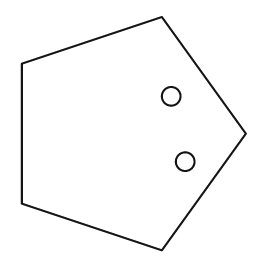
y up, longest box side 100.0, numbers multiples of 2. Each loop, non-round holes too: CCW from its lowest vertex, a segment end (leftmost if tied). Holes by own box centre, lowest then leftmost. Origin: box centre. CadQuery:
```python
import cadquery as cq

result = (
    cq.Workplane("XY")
    .moveTo(12.0, -50.0)
    .lineTo(48.0, 0.0)
    .lineTo(12.0, 50.0)
    .lineTo(-48.0, 30.0)
    .lineTo(-48.0, -30.0)
    .close()
    .moveTo(22.0, -12.0)
    .circle(4.0)
    .moveTo(16.0, 16.0)
    .circle(4.0)
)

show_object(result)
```